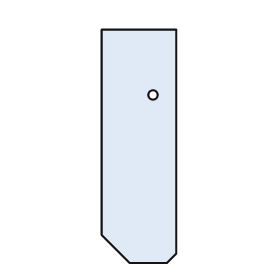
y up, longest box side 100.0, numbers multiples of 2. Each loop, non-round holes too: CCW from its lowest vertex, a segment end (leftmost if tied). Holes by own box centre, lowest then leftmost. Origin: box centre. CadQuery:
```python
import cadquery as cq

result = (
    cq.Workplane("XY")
    .moveTo(-4.0, -50.0)
    .lineTo(12.0, -50.0)
    .lineTo(16.0, -46.0)
    .lineTo(16.0, 50.0)
    .lineTo(-16.0, 50.0)
    .lineTo(-16.0, -38.0)
    .close()
    .moveTo(6.0, 22.0)
    .circle(2.0)
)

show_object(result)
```